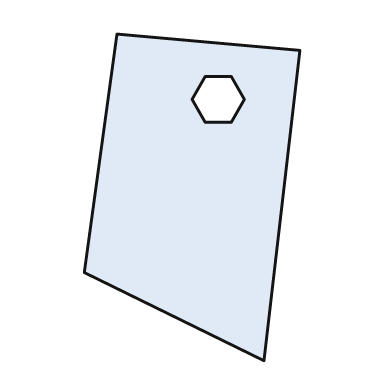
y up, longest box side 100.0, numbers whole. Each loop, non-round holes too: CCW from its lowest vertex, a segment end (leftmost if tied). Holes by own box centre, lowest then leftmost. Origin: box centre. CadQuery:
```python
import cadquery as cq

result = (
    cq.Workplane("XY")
    .moveTo(22.0, -50.0)
    .lineTo(33.0, 45.0)
    .lineTo(-23.0, 50.0)
    .lineTo(-33.0, -23.0)
    .close()
    .moveTo(4.0, 23.0)
    .lineTo(12.0, 23.0)
    .lineTo(16.0, 30.0)
    .lineTo(12.0, 37.0)
    .lineTo(4.0, 37.0)
    .lineTo(0.0, 30.0)
    .close()
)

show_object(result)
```